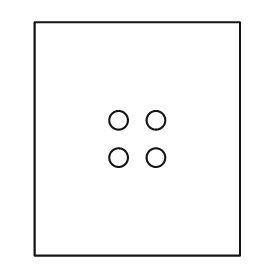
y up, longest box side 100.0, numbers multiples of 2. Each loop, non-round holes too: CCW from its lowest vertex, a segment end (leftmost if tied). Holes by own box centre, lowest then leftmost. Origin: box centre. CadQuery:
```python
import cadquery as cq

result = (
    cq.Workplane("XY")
    .moveTo(-44.0, -50.0)
    .lineTo(44.0, -50.0)
    .lineTo(44.0, 50.0)
    .lineTo(-44.0, 50.0)
    .close()
    .moveTo(-8.0, -8.0)
    .circle(4.0)
    .moveTo(8.0, -8.0)
    .circle(4.0)
    .moveTo(-8.0, 8.0)
    .circle(4.0)
    .moveTo(8.0, 8.0)
    .circle(4.0)
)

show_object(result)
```